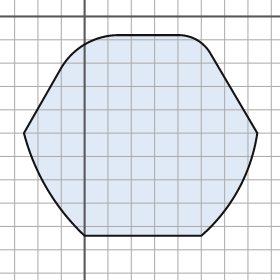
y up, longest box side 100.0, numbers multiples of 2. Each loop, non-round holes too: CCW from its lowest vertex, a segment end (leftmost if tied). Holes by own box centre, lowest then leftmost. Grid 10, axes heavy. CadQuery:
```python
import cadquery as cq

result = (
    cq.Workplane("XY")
    .moveTo(0.0, -94.0)
    .lineTo(50.0, -94.0)
    .threePointArc((66.0, -74.0), (74.0, -50.0))
    .lineTo(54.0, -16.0)
    .threePointArc((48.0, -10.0), (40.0, -8.0))
    .lineTo(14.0, -8.0)
    .threePointArc((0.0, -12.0), (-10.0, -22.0))
    .lineTo(-26.0, -50.0)
    .threePointArc((-16.0, -74.0), (0.0, -94.0))
    .close()
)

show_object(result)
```